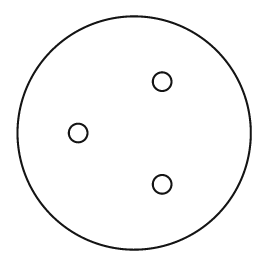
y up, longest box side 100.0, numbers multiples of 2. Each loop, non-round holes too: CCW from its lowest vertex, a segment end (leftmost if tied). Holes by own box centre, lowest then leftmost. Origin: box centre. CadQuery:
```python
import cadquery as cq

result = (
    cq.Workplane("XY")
    .moveTo(0.0, 0.0)
    .circle(50.0)
    .moveTo(12.0, -22.0)
    .circle(4.0)
    .moveTo(-24.0, 0.0)
    .circle(4.0)
    .moveTo(12.0, 22.0)
    .circle(4.0)
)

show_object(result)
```